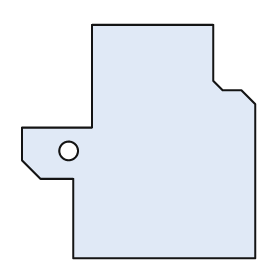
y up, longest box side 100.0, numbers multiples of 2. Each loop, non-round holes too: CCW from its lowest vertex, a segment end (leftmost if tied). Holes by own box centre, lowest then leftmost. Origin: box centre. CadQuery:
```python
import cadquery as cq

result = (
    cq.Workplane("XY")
    .moveTo(-28.0, -50.0)
    .lineTo(50.0, -50.0)
    .lineTo(50.0, 16.0)
    .lineTo(44.0, 22.0)
    .lineTo(36.0, 22.0)
    .lineTo(32.0, 26.0)
    .lineTo(32.0, 50.0)
    .lineTo(-20.0, 50.0)
    .lineTo(-20.0, 6.0)
    .lineTo(-50.0, 6.0)
    .lineTo(-50.0, -8.0)
    .lineTo(-42.0, -16.0)
    .lineTo(-28.0, -16.0)
    .close()
    .moveTo(-30.0, -4.0)
    .circle(4.0)
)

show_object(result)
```